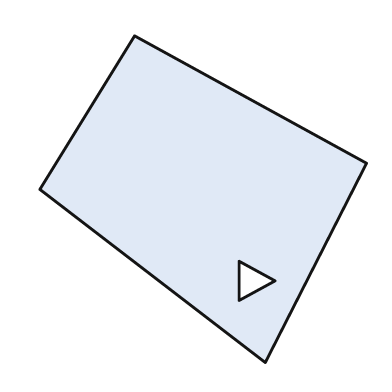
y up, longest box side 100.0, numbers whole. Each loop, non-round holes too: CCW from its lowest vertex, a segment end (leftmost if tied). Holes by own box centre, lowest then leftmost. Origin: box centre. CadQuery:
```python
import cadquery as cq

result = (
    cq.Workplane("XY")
    .moveTo(19.0, -50.0)
    .lineTo(50.0, 11.0)
    .lineTo(-21.0, 50.0)
    .lineTo(-50.0, 3.0)
    .close()
    .moveTo(11.0, -31.0)
    .lineTo(22.0, -25.0)
    .lineTo(11.0, -19.0)
    .close()
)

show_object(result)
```